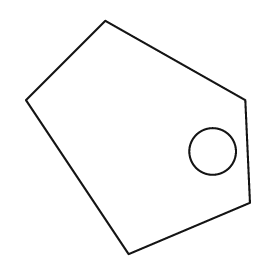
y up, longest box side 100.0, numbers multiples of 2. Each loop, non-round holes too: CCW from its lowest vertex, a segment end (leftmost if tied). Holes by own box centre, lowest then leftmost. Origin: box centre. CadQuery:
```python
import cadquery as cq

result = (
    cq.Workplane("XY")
    .moveTo(-4.0, -50.0)
    .lineTo(48.0, -28.0)
    .lineTo(46.0, 16.0)
    .lineTo(-14.0, 50.0)
    .lineTo(-48.0, 16.0)
    .close()
    .moveTo(32.0, -6.0)
    .circle(10.0)
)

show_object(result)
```